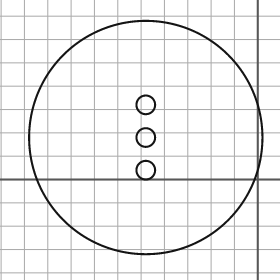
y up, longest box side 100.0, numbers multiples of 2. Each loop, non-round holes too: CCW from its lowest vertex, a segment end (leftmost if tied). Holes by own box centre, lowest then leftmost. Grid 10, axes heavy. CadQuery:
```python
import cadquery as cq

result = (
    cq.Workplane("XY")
    .moveTo(-48.0, 18.0)
    .circle(50.0)
    .moveTo(-48.0, 4.0)
    .circle(4.0)
    .moveTo(-48.0, 18.0)
    .circle(4.0)
    .moveTo(-48.0, 32.0)
    .circle(4.0)
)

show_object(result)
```